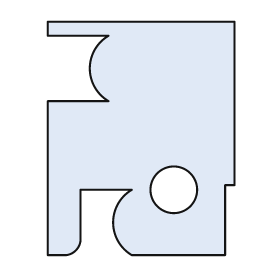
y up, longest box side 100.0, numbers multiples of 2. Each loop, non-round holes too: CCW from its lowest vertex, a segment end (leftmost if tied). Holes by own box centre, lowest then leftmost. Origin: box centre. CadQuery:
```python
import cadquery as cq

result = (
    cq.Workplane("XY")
    .moveTo(-40.0, -50.0)
    .lineTo(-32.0, -50.0)
    .threePointArc((-28.0, -48.0), (-26.0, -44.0))
    .lineTo(-26.0, -22.0)
    .lineTo(-4.0, -22.0)
    .threePointArc((-12.0, -36.0), (-4.0, -50.0))
    .lineTo(36.0, -50.0)
    .lineTo(36.0, -20.0)
    .lineTo(40.0, -20.0)
    .lineTo(40.0, 50.0)
    .lineTo(-40.0, 50.0)
    .lineTo(-40.0, 44.0)
    .lineTo(-14.0, 44.0)
    .threePointArc((-22.0, 30.0), (-14.0, 16.0))
    .lineTo(-40.0, 16.0)
    .close()
    .moveTo(14.0, -22.0)
    .circle(10.0)
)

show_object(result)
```